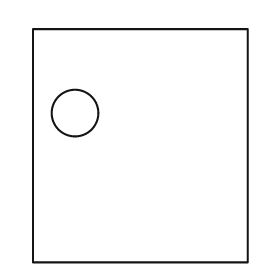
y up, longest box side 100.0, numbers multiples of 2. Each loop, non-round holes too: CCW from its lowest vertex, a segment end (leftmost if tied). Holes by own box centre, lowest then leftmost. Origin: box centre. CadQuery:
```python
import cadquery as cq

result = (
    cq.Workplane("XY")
    .moveTo(-46.0, -50.0)
    .lineTo(46.0, -50.0)
    .lineTo(46.0, 50.0)
    .lineTo(-46.0, 50.0)
    .close()
    .moveTo(-28.0, 14.0)
    .circle(10.0)
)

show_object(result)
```